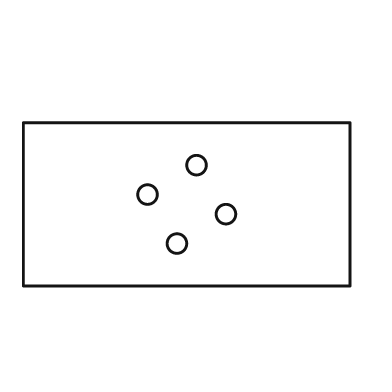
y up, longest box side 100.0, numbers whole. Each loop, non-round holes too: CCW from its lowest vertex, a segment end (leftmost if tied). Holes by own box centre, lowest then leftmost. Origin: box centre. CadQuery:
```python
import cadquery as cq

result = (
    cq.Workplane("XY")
    .moveTo(-50.0, -25.0)
    .lineTo(50.0, -25.0)
    .lineTo(50.0, 25.0)
    .lineTo(-50.0, 25.0)
    .close()
    .moveTo(-3.0, -12.0)
    .circle(3.0)
    .moveTo(12.0, -3.0)
    .circle(3.0)
    .moveTo(-12.0, 3.0)
    .circle(3.0)
    .moveTo(3.0, 12.0)
    .circle(3.0)
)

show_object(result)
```